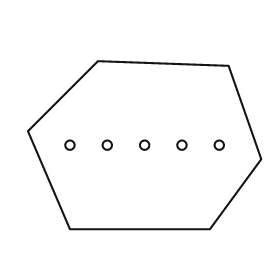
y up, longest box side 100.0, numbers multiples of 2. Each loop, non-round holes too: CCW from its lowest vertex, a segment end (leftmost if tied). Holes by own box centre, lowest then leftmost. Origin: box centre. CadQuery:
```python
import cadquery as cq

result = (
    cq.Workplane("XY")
    .moveTo(-32.0, -36.0)
    .lineTo(28.0, -36.0)
    .lineTo(50.0, -6.0)
    .lineTo(36.0, 34.0)
    .lineTo(-20.0, 36.0)
    .lineTo(-50.0, 6.0)
    .close()
    .moveTo(-32.0, 0.0)
    .circle(2.0)
    .moveTo(-16.0, 0.0)
    .circle(2.0)
    .moveTo(0.0, 0.0)
    .circle(2.0)
    .moveTo(16.0, 0.0)
    .circle(2.0)
    .moveTo(32.0, 0.0)
    .circle(2.0)
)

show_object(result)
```